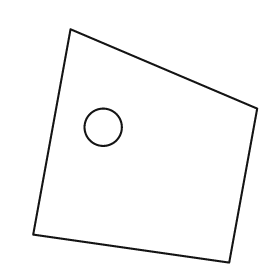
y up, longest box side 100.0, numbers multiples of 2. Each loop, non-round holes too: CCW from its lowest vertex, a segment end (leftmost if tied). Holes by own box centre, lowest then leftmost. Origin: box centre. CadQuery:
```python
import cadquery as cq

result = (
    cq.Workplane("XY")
    .moveTo(36.0, -50.0)
    .lineTo(48.0, 16.0)
    .lineTo(-32.0, 50.0)
    .lineTo(-48.0, -38.0)
    .close()
    .moveTo(-18.0, 8.0)
    .circle(8.0)
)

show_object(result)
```